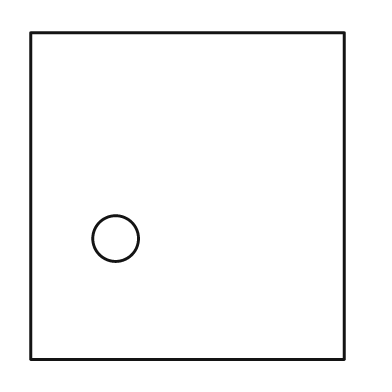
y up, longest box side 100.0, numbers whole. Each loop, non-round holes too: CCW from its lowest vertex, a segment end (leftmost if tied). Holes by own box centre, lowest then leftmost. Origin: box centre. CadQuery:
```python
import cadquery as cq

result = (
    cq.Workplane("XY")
    .moveTo(-48.0, -50.0)
    .lineTo(48.0, -50.0)
    .lineTo(48.0, 50.0)
    .lineTo(-48.0, 50.0)
    .close()
    .moveTo(-22.0, -13.0)
    .circle(7.0)
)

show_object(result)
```